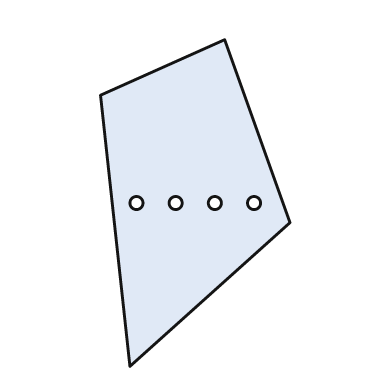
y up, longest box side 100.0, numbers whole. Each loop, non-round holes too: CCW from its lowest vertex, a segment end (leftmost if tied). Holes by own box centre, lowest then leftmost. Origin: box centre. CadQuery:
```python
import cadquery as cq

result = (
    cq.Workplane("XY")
    .moveTo(-20.0, -50.0)
    .lineTo(29.0, -6.0)
    .lineTo(9.0, 50.0)
    .lineTo(-29.0, 33.0)
    .close()
    .moveTo(-18.0, 0.0)
    .circle(2.0)
    .moveTo(-6.0, 0.0)
    .circle(2.0)
    .moveTo(6.0, 0.0)
    .circle(2.0)
    .moveTo(18.0, 0.0)
    .circle(2.0)
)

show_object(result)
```